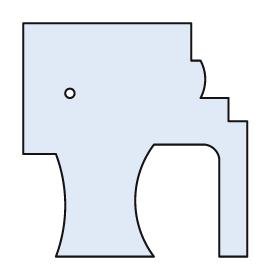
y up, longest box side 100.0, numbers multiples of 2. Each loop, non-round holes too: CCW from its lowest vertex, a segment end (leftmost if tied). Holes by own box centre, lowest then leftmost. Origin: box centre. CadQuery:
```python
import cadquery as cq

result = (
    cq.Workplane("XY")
    .moveTo(-34.0, -50.0)
    .lineTo(8.0, -50.0)
    .threePointArc((0.0, -26.0), (8.0, -2.0))
    .lineTo(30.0, -2.0)
    .threePointArc((34.0, -4.0), (36.0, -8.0))
    .lineTo(36.0, -50.0)
    .lineTo(48.0, -50.0)
    .lineTo(48.0, 8.0)
    .lineTo(40.0, 8.0)
    .lineTo(40.0, 18.0)
    .lineTo(28.0, 18.0)
    .threePointArc((30.0, 26.0), (28.0, 34.0))
    .lineTo(24.0, 34.0)
    .lineTo(24.0, 50.0)
    .lineTo(-48.0, 50.0)
    .lineTo(-48.0, -6.0)
    .lineTo(-34.0, -6.0)
    .threePointArc((-30.0, -28.0), (-34.0, -50.0))
    .close()
    .moveTo(-28.0, 20.0)
    .circle(2.0)
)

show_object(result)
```